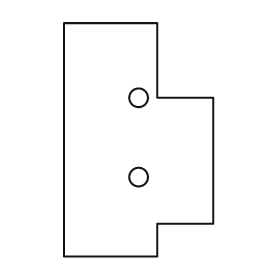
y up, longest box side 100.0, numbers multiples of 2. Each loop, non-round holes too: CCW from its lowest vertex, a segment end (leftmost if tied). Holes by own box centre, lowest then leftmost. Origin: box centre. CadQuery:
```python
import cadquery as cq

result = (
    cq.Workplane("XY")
    .moveTo(-32.0, -50.0)
    .lineTo(8.0, -50.0)
    .lineTo(8.0, -36.0)
    .lineTo(32.0, -36.0)
    .lineTo(32.0, 18.0)
    .lineTo(8.0, 18.0)
    .lineTo(8.0, 50.0)
    .lineTo(-32.0, 50.0)
    .close()
    .moveTo(0.0, -16.0)
    .circle(4.0)
    .moveTo(0.0, 18.0)
    .circle(4.0)
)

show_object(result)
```